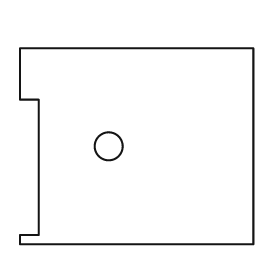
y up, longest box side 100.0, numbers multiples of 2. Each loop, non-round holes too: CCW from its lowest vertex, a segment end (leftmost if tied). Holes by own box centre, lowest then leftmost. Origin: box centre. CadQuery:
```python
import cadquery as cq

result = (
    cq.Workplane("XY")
    .moveTo(-50.0, -42.0)
    .lineTo(50.0, -42.0)
    .lineTo(50.0, 42.0)
    .lineTo(-50.0, 42.0)
    .lineTo(-50.0, 20.0)
    .lineTo(-42.0, 20.0)
    .lineTo(-42.0, -38.0)
    .lineTo(-50.0, -38.0)
    .close()
    .moveTo(-12.0, 0.0)
    .circle(6.0)
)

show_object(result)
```